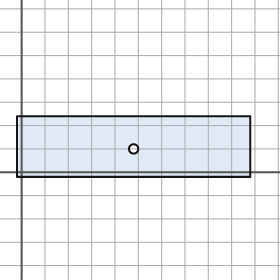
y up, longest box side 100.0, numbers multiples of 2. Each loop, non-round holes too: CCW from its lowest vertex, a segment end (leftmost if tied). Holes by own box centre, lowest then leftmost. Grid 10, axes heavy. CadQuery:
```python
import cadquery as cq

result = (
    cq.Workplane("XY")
    .moveTo(-2.0, -2.0)
    .lineTo(98.0, -2.0)
    .lineTo(98.0, 24.0)
    .lineTo(-2.0, 24.0)
    .close()
    .moveTo(48.0, 10.0)
    .circle(2.0)
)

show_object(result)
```